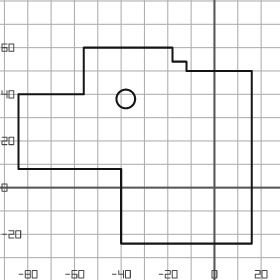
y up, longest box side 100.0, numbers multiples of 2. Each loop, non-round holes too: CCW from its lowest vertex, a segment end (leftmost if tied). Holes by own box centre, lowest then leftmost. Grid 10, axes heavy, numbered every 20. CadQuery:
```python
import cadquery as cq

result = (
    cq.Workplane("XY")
    .moveTo(-40.0, -24.0)
    .lineTo(16.0, -24.0)
    .lineTo(16.0, 50.0)
    .lineTo(-12.0, 50.0)
    .lineTo(-12.0, 54.0)
    .lineTo(-18.0, 54.0)
    .lineTo(-18.0, 60.0)
    .lineTo(-56.0, 60.0)
    .lineTo(-56.0, 40.0)
    .lineTo(-84.0, 40.0)
    .lineTo(-84.0, 8.0)
    .lineTo(-40.0, 8.0)
    .close()
    .moveTo(-38.0, 38.0)
    .circle(4.0)
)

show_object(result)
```